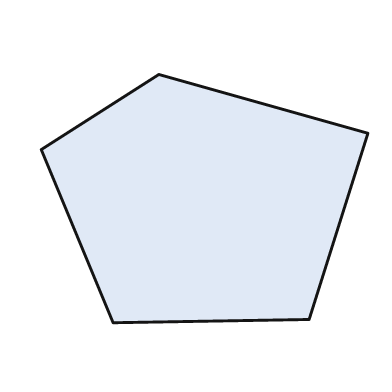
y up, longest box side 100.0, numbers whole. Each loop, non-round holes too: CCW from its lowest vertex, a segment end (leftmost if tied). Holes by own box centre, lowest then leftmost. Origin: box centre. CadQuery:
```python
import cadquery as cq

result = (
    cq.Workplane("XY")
    .moveTo(-28.0, -38.0)
    .lineTo(32.0, -37.0)
    .lineTo(50.0, 20.0)
    .lineTo(-14.0, 38.0)
    .lineTo(-50.0, 15.0)
    .close()
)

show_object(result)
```